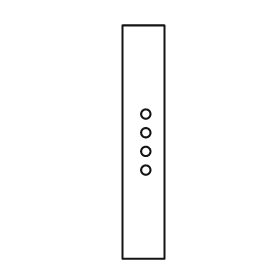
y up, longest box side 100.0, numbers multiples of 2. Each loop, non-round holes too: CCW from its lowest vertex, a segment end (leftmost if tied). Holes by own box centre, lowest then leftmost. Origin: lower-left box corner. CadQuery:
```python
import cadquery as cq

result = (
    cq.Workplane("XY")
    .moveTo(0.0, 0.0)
    .lineTo(18.0, 0.0)
    .lineTo(18.0, 100.0)
    .lineTo(0.0, 100.0)
    .close()
    .moveTo(10.0, 38.0)
    .circle(2.0)
    .moveTo(10.0, 46.0)
    .circle(2.0)
    .moveTo(10.0, 54.0)
    .circle(2.0)
    .moveTo(10.0, 62.0)
    .circle(2.0)
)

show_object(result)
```